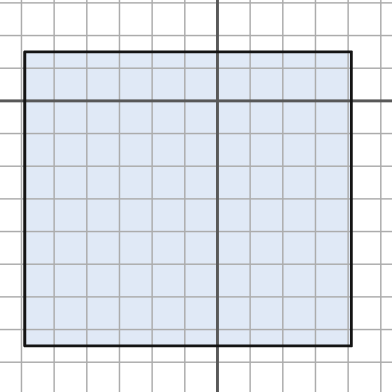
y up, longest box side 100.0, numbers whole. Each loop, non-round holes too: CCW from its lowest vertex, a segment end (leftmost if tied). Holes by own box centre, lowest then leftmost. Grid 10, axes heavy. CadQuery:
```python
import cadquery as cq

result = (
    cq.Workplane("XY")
    .moveTo(-59.0, -75.0)
    .lineTo(41.0, -75.0)
    .lineTo(41.0, 15.0)
    .lineTo(-59.0, 15.0)
    .close()
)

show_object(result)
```